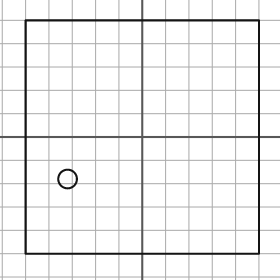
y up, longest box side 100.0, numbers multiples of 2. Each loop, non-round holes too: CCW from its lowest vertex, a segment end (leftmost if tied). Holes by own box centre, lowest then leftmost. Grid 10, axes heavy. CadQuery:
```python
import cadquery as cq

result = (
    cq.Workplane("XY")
    .moveTo(-50.0, -50.0)
    .lineTo(50.0, -50.0)
    .lineTo(50.0, 50.0)
    .lineTo(-50.0, 50.0)
    .close()
    .moveTo(-32.0, -18.0)
    .circle(4.0)
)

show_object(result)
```